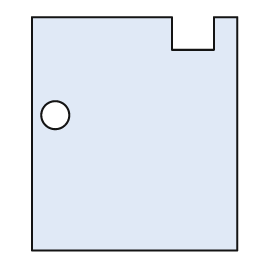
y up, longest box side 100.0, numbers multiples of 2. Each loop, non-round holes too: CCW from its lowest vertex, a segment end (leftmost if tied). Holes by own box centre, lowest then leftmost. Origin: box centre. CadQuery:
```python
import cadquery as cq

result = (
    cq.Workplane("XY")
    .moveTo(-44.0, -50.0)
    .lineTo(44.0, -50.0)
    .lineTo(44.0, 50.0)
    .lineTo(34.0, 50.0)
    .lineTo(34.0, 36.0)
    .lineTo(16.0, 36.0)
    .lineTo(16.0, 50.0)
    .lineTo(-44.0, 50.0)
    .close()
    .moveTo(-34.0, 8.0)
    .circle(6.0)
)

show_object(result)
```